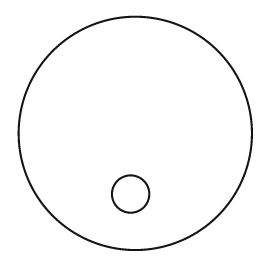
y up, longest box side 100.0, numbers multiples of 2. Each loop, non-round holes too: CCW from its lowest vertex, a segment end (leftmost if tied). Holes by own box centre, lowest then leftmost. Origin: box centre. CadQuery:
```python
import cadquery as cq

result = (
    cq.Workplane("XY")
    .moveTo(0.0, 0.0)
    .circle(50.0)
    .moveTo(-2.0, -26.0)
    .circle(8.0)
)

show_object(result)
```